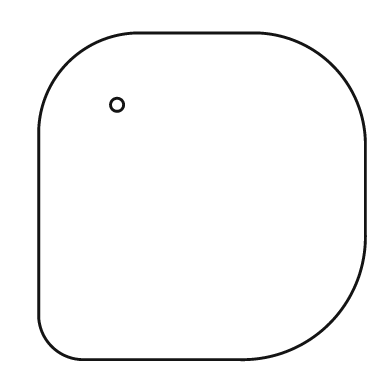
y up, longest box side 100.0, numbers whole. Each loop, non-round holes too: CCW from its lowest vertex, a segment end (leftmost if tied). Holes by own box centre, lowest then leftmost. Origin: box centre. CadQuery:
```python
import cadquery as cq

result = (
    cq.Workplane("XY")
    .moveTo(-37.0, -50.0)
    .lineTo(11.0, -50.0)
    .threePointArc((39.0, -39.0), (50.0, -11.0))
    .lineTo(50.0, 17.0)
    .threePointArc((40.0, 40.0), (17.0, 50.0))
    .lineTo(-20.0, 50.0)
    .threePointArc((-41.0, 41.0), (-50.0, 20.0))
    .lineTo(-50.0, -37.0)
    .threePointArc((-46.0, -46.0), (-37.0, -50.0))
    .close()
    .moveTo(-26.0, 28.0)
    .circle(2.0)
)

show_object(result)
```